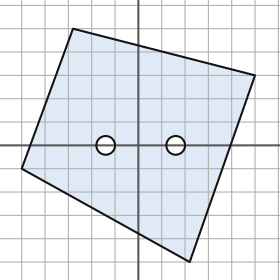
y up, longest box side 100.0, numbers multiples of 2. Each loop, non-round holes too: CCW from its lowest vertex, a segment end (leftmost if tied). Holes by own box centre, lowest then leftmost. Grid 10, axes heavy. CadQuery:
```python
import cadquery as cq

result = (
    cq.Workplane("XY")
    .moveTo(22.0, -50.0)
    .lineTo(50.0, 30.0)
    .lineTo(-28.0, 50.0)
    .lineTo(-50.0, -10.0)
    .close()
    .moveTo(-14.0, 0.0)
    .circle(4.0)
    .moveTo(16.0, 0.0)
    .circle(4.0)
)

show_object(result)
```